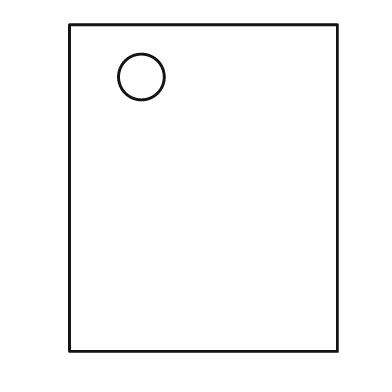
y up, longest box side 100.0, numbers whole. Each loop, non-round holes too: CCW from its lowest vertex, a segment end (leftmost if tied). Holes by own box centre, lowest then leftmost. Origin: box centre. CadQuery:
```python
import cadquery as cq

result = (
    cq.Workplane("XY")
    .moveTo(-41.0, -50.0)
    .lineTo(41.0, -50.0)
    .lineTo(41.0, 50.0)
    .lineTo(-41.0, 50.0)
    .close()
    .moveTo(-19.0, 34.0)
    .circle(7.0)
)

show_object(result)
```